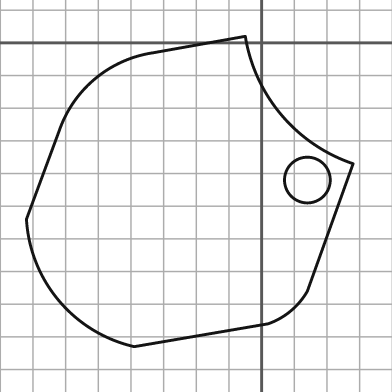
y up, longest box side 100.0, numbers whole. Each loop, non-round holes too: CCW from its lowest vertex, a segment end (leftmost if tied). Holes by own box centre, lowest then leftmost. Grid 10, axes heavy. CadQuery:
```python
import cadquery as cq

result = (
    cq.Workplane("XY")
    .moveTo(-39.0, -93.0)
    .lineTo(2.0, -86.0)
    .threePointArc((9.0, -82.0), (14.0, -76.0))
    .lineTo(28.0, -37.0)
    .threePointArc((6.0, -22.0), (-5.0, 2.0))
    .lineTo(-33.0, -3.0)
    .threePointArc((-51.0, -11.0), (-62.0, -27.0))
    .lineTo(-72.0, -54.0)
    .threePointArc((-62.0, -79.0), (-39.0, -93.0))
    .close()
    .moveTo(14.0, -42.0)
    .circle(7.0)
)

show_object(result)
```